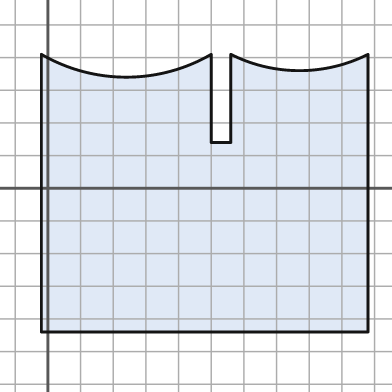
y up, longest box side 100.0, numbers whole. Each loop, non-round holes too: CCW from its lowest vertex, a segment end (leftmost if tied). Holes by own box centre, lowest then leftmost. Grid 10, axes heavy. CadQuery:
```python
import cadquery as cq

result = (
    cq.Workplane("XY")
    .moveTo(-2.0, -44.0)
    .lineTo(98.0, -44.0)
    .lineTo(98.0, 41.0)
    .threePointArc((77.0, 36.0), (56.0, 41.0))
    .lineTo(56.0, 14.0)
    .lineTo(50.0, 14.0)
    .lineTo(50.0, 41.0)
    .threePointArc((24.0, 34.0), (-2.0, 41.0))
    .close()
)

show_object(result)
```